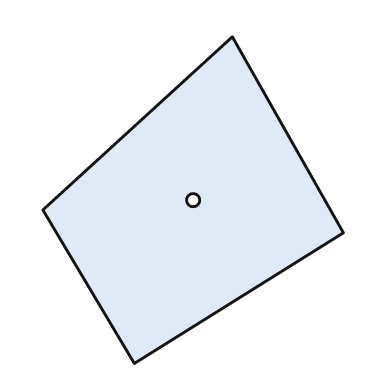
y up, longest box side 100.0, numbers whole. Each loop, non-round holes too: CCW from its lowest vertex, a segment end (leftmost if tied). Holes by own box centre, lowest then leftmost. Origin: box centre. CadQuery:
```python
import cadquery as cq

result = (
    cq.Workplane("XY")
    .moveTo(-18.0, -50.0)
    .lineTo(46.0, -10.0)
    .lineTo(12.0, 50.0)
    .lineTo(-46.0, -3.0)
    .close()
    .moveTo(0.0, 0.0)
    .circle(2.0)
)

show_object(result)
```